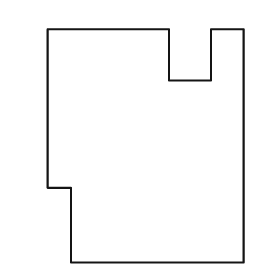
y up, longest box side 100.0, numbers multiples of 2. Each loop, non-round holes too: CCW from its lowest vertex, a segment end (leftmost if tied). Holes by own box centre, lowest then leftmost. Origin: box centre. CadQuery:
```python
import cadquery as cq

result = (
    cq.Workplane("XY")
    .moveTo(-32.0, -50.0)
    .lineTo(42.0, -50.0)
    .lineTo(42.0, 50.0)
    .lineTo(28.0, 50.0)
    .lineTo(28.0, 28.0)
    .lineTo(10.0, 28.0)
    .lineTo(10.0, 50.0)
    .lineTo(-42.0, 50.0)
    .lineTo(-42.0, -18.0)
    .lineTo(-32.0, -18.0)
    .close()
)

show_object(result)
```